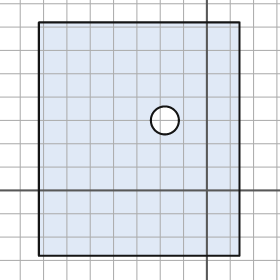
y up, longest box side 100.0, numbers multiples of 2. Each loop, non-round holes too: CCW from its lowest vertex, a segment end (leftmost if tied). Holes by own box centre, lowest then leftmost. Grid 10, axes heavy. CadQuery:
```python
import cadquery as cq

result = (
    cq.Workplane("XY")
    .moveTo(-72.0, -28.0)
    .lineTo(14.0, -28.0)
    .lineTo(14.0, 72.0)
    .lineTo(-72.0, 72.0)
    .close()
    .moveTo(-18.0, 30.0)
    .circle(6.0)
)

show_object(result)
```